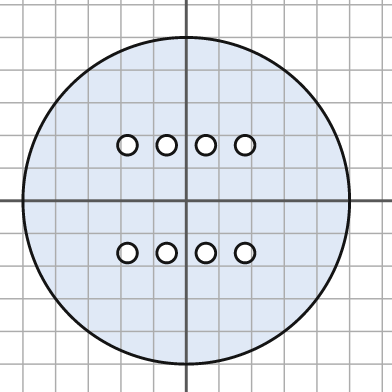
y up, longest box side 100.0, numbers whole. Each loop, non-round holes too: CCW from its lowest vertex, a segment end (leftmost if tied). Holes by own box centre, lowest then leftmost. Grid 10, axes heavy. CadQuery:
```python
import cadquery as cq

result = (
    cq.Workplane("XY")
    .moveTo(0.0, 0.0)
    .circle(50.0)
    .moveTo(-18.0, -16.0)
    .circle(3.0)
    .moveTo(-6.0, -16.0)
    .circle(3.0)
    .moveTo(6.0, -16.0)
    .circle(3.0)
    .moveTo(18.0, -16.0)
    .circle(3.0)
    .moveTo(-18.0, 17.0)
    .circle(3.0)
    .moveTo(-6.0, 17.0)
    .circle(3.0)
    .moveTo(6.0, 17.0)
    .circle(3.0)
    .moveTo(18.0, 17.0)
    .circle(3.0)
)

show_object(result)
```